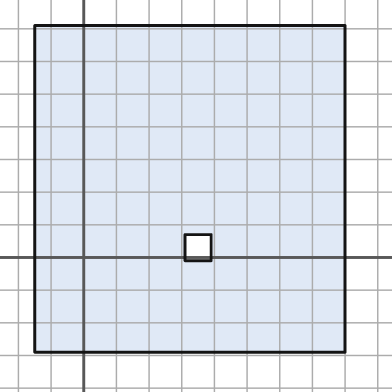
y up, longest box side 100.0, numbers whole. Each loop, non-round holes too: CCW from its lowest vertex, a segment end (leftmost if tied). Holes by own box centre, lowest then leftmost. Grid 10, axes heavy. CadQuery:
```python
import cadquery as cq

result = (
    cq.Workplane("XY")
    .moveTo(-15.0, -29.0)
    .lineTo(80.0, -29.0)
    .lineTo(80.0, 71.0)
    .lineTo(-15.0, 71.0)
    .close()
    .moveTo(31.0, -1.0)
    .lineTo(39.0, -1.0)
    .lineTo(39.0, 7.0)
    .lineTo(31.0, 7.0)
    .close()
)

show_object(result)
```